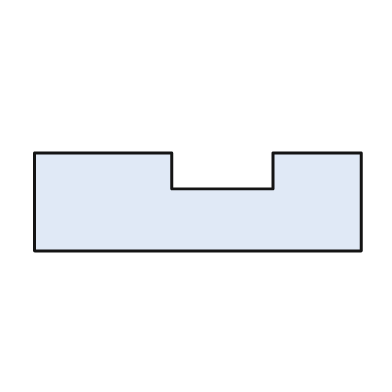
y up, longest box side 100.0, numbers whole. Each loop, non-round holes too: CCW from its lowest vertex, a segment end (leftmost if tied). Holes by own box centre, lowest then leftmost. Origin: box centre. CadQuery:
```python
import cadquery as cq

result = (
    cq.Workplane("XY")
    .moveTo(-50.0, -15.0)
    .lineTo(50.0, -15.0)
    .lineTo(50.0, 15.0)
    .lineTo(23.0, 15.0)
    .lineTo(23.0, 4.0)
    .lineTo(-8.0, 4.0)
    .lineTo(-8.0, 15.0)
    .lineTo(-50.0, 15.0)
    .close()
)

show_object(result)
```